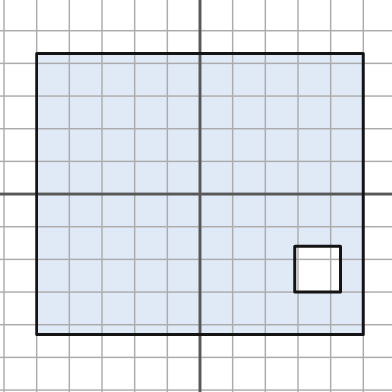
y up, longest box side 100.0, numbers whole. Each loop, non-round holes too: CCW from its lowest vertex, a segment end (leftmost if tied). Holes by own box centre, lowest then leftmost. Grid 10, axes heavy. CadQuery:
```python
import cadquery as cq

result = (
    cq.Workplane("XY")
    .moveTo(-50.0, -43.0)
    .lineTo(50.0, -43.0)
    .lineTo(50.0, 43.0)
    .lineTo(-50.0, 43.0)
    .close()
    .moveTo(29.0, -30.0)
    .lineTo(43.0, -30.0)
    .lineTo(43.0, -16.0)
    .lineTo(29.0, -16.0)
    .close()
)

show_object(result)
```